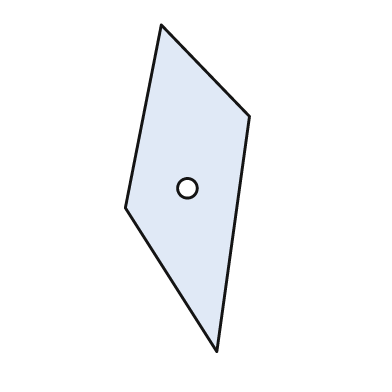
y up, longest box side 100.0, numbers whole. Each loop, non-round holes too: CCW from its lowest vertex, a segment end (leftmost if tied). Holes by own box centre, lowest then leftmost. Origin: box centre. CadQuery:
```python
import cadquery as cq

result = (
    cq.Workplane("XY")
    .moveTo(9.0, -50.0)
    .lineTo(19.0, 22.0)
    .lineTo(-8.0, 50.0)
    .lineTo(-19.0, -6.0)
    .close()
    .moveTo(0.0, 0.0)
    .circle(3.0)
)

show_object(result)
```